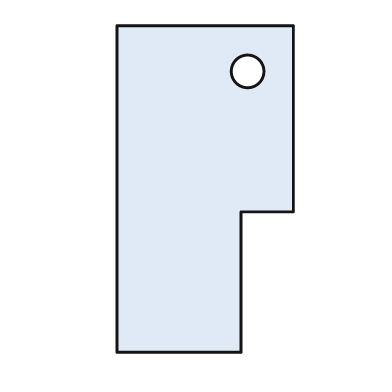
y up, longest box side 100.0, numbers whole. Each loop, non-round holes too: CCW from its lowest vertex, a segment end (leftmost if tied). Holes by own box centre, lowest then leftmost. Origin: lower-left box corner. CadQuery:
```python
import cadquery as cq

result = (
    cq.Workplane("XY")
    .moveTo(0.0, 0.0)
    .lineTo(38.0, 0.0)
    .lineTo(38.0, 43.0)
    .lineTo(54.0, 43.0)
    .lineTo(54.0, 100.0)
    .lineTo(0.0, 100.0)
    .close()
    .moveTo(40.0, 86.0)
    .circle(5.0)
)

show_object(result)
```